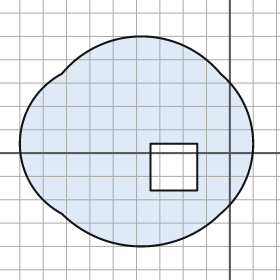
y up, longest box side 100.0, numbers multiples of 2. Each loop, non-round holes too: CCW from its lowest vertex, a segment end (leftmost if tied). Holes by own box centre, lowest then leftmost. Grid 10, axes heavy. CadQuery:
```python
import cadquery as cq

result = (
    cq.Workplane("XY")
    .moveTo(-72.0, -26.0)
    .threePointArc((-38.0, -40.0), (-4.0, -26.0))
    .threePointArc((10.0, 4.0), (-4.0, 34.0))
    .threePointArc((-38.0, 50.0), (-72.0, 34.0))
    .threePointArc((-90.0, 4.0), (-72.0, -26.0))
    .close()
    .moveTo(-34.0, -16.0)
    .lineTo(-14.0, -16.0)
    .lineTo(-14.0, 4.0)
    .lineTo(-34.0, 4.0)
    .close()
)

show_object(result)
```